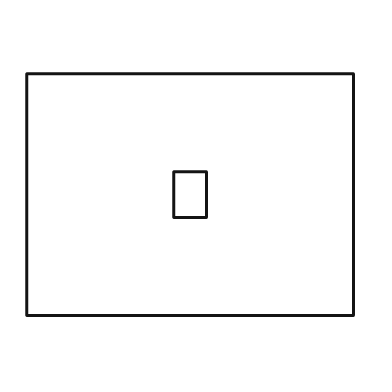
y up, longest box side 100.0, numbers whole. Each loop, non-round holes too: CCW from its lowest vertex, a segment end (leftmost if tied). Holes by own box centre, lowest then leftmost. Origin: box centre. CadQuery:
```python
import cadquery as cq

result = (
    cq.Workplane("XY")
    .moveTo(-50.0, -37.0)
    .lineTo(50.0, -37.0)
    .lineTo(50.0, 37.0)
    .lineTo(-50.0, 37.0)
    .close()
    .moveTo(-5.0, -7.0)
    .lineTo(5.0, -7.0)
    .lineTo(5.0, 7.0)
    .lineTo(-5.0, 7.0)
    .close()
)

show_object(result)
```